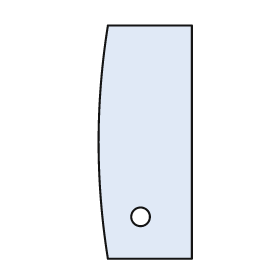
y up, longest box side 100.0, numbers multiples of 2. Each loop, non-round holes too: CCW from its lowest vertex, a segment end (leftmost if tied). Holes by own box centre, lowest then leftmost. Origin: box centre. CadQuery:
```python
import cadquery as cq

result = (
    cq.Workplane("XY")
    .moveTo(-16.0, -50.0)
    .lineTo(20.0, -50.0)
    .lineTo(20.0, 50.0)
    .lineTo(-16.0, 50.0)
    .threePointArc((-20.0, 0.0), (-16.0, -50.0))
    .close()
    .moveTo(-2.0, -32.0)
    .circle(4.0)
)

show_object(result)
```